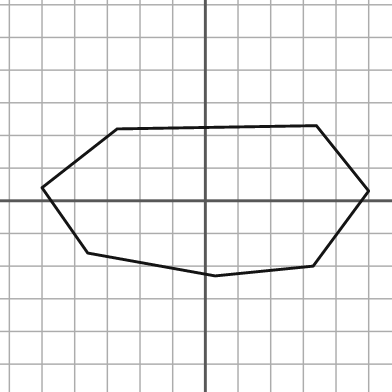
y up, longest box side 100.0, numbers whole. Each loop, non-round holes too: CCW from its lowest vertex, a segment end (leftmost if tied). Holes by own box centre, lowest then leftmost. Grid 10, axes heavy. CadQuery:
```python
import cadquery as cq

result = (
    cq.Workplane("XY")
    .moveTo(3.0, -23.0)
    .lineTo(33.0, -20.0)
    .lineTo(50.0, 3.0)
    .lineTo(34.0, 23.0)
    .lineTo(-27.0, 22.0)
    .lineTo(-50.0, 4.0)
    .lineTo(-36.0, -16.0)
    .close()
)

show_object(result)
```